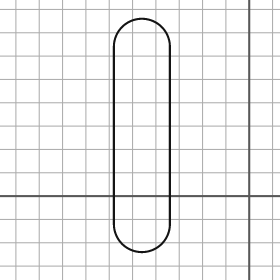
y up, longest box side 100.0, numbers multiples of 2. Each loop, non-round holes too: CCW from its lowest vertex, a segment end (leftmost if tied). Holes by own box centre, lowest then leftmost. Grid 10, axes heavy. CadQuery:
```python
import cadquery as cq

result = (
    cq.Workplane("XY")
    .moveTo(-58.0, -12.0)
    .threePointArc((-46.0, -24.0), (-34.0, -12.0))
    .lineTo(-34.0, 64.0)
    .threePointArc((-46.0, 76.0), (-58.0, 64.0))
    .close()
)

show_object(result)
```